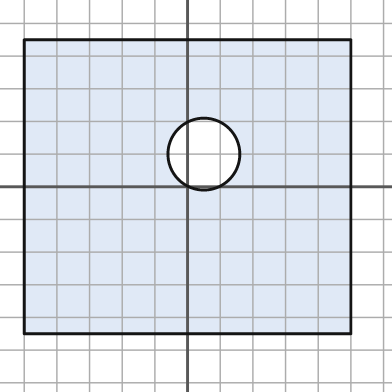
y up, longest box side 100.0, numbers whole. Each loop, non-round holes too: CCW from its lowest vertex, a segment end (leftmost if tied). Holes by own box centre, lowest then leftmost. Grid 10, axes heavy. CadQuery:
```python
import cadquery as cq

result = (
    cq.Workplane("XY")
    .moveTo(-50.0, -45.0)
    .lineTo(50.0, -45.0)
    .lineTo(50.0, 45.0)
    .lineTo(-50.0, 45.0)
    .close()
    .moveTo(5.0, 10.0)
    .circle(11.0)
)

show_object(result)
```